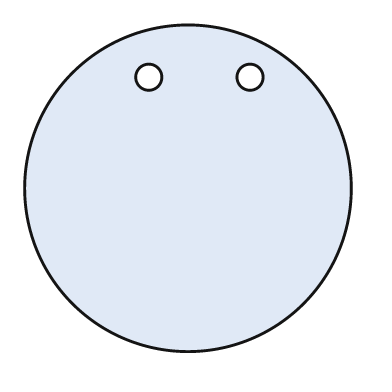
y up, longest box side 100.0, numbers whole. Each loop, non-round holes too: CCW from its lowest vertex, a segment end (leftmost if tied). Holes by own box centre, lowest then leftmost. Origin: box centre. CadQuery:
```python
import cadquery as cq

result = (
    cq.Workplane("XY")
    .moveTo(0.0, 0.0)
    .circle(50.0)
    .moveTo(-12.0, 34.0)
    .circle(4.0)
    .moveTo(19.0, 34.0)
    .circle(4.0)
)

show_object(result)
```